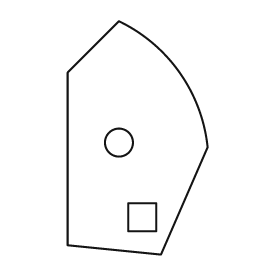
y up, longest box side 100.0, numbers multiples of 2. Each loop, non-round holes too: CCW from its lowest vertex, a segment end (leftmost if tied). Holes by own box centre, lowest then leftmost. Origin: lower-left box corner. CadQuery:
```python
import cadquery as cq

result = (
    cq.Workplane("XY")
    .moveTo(40.0, 0.0)
    .lineTo(60.0, 46.0)
    .threePointArc((48.0, 78.0), (22.0, 100.0))
    .lineTo(0.0, 78.0)
    .lineTo(0.0, 4.0)
    .close()
    .moveTo(26.0, 10.0)
    .lineTo(38.0, 10.0)
    .lineTo(38.0, 22.0)
    .lineTo(26.0, 22.0)
    .close()
    .moveTo(22.0, 48.0)
    .circle(6.0)
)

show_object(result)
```